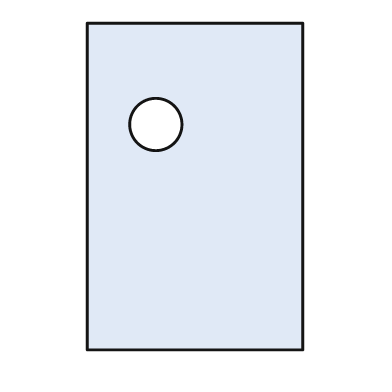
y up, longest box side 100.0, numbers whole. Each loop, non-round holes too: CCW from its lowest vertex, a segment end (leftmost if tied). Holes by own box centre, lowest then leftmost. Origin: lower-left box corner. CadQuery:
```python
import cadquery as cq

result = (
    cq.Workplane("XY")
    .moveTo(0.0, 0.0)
    .lineTo(66.0, 0.0)
    .lineTo(66.0, 100.0)
    .lineTo(0.0, 100.0)
    .close()
    .moveTo(21.0, 69.0)
    .circle(8.0)
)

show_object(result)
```